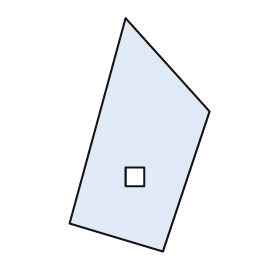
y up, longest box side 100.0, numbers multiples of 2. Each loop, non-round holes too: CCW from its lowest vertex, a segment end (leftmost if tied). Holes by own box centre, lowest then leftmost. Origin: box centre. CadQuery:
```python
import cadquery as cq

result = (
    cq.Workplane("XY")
    .moveTo(10.0, -50.0)
    .lineTo(30.0, 10.0)
    .lineTo(-6.0, 50.0)
    .lineTo(-30.0, -38.0)
    .close()
    .moveTo(-6.0, -22.0)
    .lineTo(2.0, -22.0)
    .lineTo(2.0, -14.0)
    .lineTo(-6.0, -14.0)
    .close()
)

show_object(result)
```